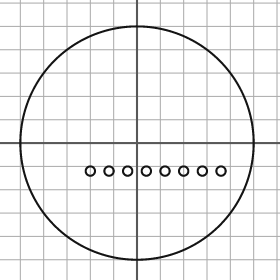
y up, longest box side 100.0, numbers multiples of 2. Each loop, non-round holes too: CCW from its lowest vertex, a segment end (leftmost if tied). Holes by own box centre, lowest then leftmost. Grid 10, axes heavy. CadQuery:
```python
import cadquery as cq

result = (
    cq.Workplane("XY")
    .moveTo(0.0, 0.0)
    .circle(50.0)
    .moveTo(-20.0, -12.0)
    .circle(2.0)
    .moveTo(-12.0, -12.0)
    .circle(2.0)
    .moveTo(-4.0, -12.0)
    .circle(2.0)
    .moveTo(4.0, -12.0)
    .circle(2.0)
    .moveTo(12.0, -12.0)
    .circle(2.0)
    .moveTo(20.0, -12.0)
    .circle(2.0)
    .moveTo(28.0, -12.0)
    .circle(2.0)
    .moveTo(36.0, -12.0)
    .circle(2.0)
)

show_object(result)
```